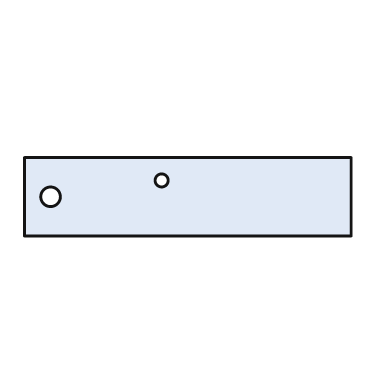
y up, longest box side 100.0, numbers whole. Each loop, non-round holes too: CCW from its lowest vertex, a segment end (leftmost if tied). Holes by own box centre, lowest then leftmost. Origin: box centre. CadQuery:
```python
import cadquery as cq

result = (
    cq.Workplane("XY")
    .moveTo(-50.0, -12.0)
    .lineTo(50.0, -12.0)
    .lineTo(50.0, 12.0)
    .lineTo(-50.0, 12.0)
    .close()
    .moveTo(-42.0, 0.0)
    .circle(3.0)
    .moveTo(-8.0, 5.0)
    .circle(2.0)
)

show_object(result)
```